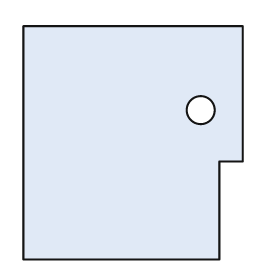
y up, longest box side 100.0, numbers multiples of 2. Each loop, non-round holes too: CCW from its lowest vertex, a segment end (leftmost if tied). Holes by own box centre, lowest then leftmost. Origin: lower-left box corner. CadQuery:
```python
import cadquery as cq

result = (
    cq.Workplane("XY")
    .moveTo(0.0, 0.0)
    .lineTo(84.0, 0.0)
    .lineTo(84.0, 42.0)
    .lineTo(94.0, 42.0)
    .lineTo(94.0, 100.0)
    .lineTo(0.0, 100.0)
    .close()
    .moveTo(76.0, 64.0)
    .circle(6.0)
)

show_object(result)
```